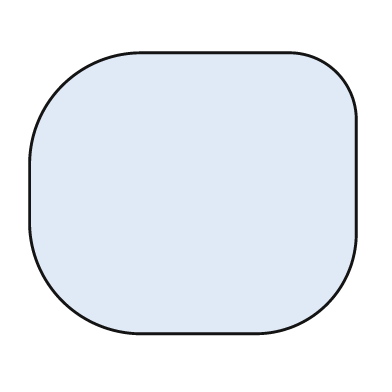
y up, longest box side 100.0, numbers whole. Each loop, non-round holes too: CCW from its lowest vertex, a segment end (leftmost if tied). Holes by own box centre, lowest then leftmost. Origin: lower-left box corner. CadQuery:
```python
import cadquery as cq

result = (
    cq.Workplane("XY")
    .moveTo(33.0, 0.0)
    .lineTo(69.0, 0.0)
    .threePointArc((91.0, 9.0), (100.0, 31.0))
    .lineTo(100.0, 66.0)
    .threePointArc((94.0, 80.0), (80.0, 86.0))
    .lineTo(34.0, 86.0)
    .threePointArc((10.0, 76.0), (0.0, 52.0))
    .lineTo(0.0, 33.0)
    .threePointArc((10.0, 10.0), (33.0, 0.0))
    .close()
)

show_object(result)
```